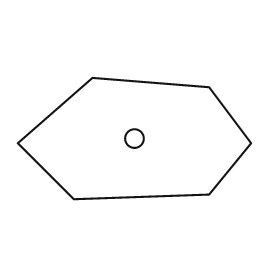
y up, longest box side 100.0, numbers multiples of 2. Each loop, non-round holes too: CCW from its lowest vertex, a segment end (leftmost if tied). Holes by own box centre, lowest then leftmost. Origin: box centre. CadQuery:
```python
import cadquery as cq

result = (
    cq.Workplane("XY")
    .moveTo(-26.0, -26.0)
    .lineTo(32.0, -24.0)
    .lineTo(50.0, -2.0)
    .lineTo(32.0, 22.0)
    .lineTo(-18.0, 26.0)
    .lineTo(-50.0, -2.0)
    .close()
    .moveTo(0.0, 0.0)
    .circle(4.0)
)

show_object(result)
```